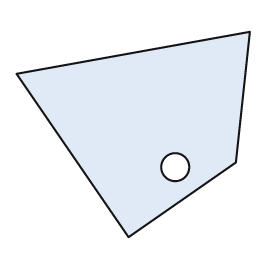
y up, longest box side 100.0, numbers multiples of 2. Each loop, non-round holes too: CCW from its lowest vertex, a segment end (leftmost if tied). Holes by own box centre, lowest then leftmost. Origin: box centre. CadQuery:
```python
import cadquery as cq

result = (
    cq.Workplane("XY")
    .moveTo(-2.0, -44.0)
    .lineTo(44.0, -12.0)
    .lineTo(50.0, 44.0)
    .lineTo(-50.0, 26.0)
    .close()
    .moveTo(18.0, -14.0)
    .circle(6.0)
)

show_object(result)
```